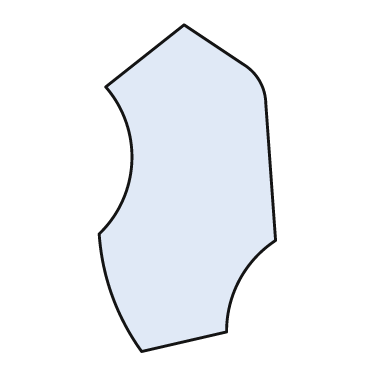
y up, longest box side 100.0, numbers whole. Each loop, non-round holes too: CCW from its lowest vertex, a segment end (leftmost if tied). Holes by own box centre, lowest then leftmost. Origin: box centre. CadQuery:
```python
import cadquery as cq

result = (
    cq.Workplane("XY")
    .moveTo(-14.0, -50.0)
    .lineTo(12.0, -44.0)
    .threePointArc((16.0, -28.0), (27.0, -16.0))
    .lineTo(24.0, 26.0)
    .threePointArc((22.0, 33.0), (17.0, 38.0))
    .lineTo(-1.0, 50.0)
    .lineTo(-25.0, 31.0)
    .threePointArc((-17.0, 8.0), (-27.0, -14.0))
    .threePointArc((-23.0, -33.0), (-14.0, -50.0))
    .close()
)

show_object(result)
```